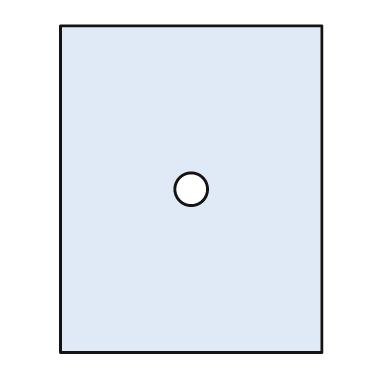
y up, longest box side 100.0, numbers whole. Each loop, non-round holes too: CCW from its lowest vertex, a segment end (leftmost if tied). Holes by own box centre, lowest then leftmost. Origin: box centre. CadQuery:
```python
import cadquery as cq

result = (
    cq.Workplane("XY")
    .moveTo(-40.0, -50.0)
    .lineTo(40.0, -50.0)
    .lineTo(40.0, 50.0)
    .lineTo(-40.0, 50.0)
    .close()
    .moveTo(0.0, 0.0)
    .circle(5.0)
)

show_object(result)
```